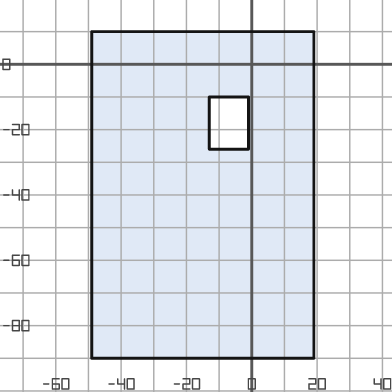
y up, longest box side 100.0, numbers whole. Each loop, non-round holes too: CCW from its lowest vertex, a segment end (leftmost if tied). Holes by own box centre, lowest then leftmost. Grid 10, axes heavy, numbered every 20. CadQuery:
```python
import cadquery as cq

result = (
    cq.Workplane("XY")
    .moveTo(-49.0, -90.0)
    .lineTo(19.0, -90.0)
    .lineTo(19.0, 10.0)
    .lineTo(-49.0, 10.0)
    .close()
    .moveTo(-13.0, -26.0)
    .lineTo(-1.0, -26.0)
    .lineTo(-1.0, -10.0)
    .lineTo(-13.0, -10.0)
    .close()
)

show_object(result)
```